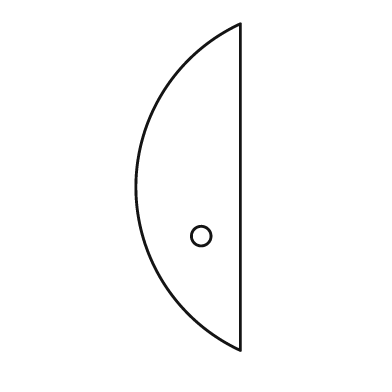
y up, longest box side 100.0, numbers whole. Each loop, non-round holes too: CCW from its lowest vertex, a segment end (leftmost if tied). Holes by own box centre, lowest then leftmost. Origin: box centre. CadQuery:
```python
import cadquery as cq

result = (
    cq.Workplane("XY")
    .moveTo(16.0, -50.0)
    .lineTo(16.0, 50.0)
    .threePointArc((-16.0, 0.0), (16.0, -50.0))
    .close()
    .moveTo(4.0, -15.0)
    .circle(3.0)
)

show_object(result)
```